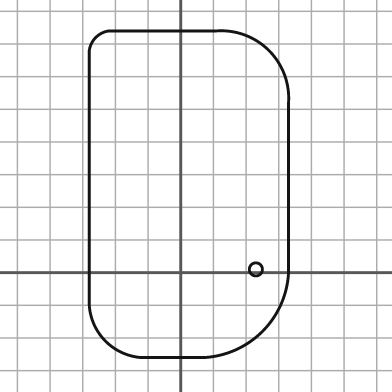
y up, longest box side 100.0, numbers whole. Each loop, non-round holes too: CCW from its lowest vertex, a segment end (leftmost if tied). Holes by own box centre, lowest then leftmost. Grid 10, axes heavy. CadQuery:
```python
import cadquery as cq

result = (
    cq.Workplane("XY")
    .moveTo(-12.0, -26.0)
    .lineTo(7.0, -26.0)
    .threePointArc((25.0, -18.0), (33.0, 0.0))
    .lineTo(33.0, 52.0)
    .threePointArc((27.0, 68.0), (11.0, 74.0))
    .lineTo(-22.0, 74.0)
    .threePointArc((-26.0, 72.0), (-28.0, 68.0))
    .lineTo(-28.0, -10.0)
    .threePointArc((-23.0, -21.0), (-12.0, -26.0))
    .close()
    .moveTo(23.0, 1.0)
    .circle(2.0)
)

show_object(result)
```